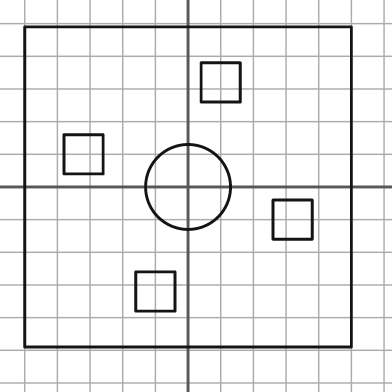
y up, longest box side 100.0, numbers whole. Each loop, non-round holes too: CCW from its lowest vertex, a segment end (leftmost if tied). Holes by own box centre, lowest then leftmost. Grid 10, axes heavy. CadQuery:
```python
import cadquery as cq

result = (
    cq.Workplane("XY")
    .moveTo(-50.0, -49.0)
    .lineTo(50.0, -49.0)
    .lineTo(50.0, 49.0)
    .lineTo(-50.0, 49.0)
    .close()
    .moveTo(-16.0, -38.0)
    .lineTo(-4.0, -38.0)
    .lineTo(-4.0, -26.0)
    .lineTo(-16.0, -26.0)
    .close()
    .moveTo(26.0, -16.0)
    .lineTo(38.0, -16.0)
    .lineTo(38.0, -4.0)
    .lineTo(26.0, -4.0)
    .close()
    .moveTo(0.0, 0.0)
    .circle(13.0)
    .moveTo(-38.0, 4.0)
    .lineTo(-26.0, 4.0)
    .lineTo(-26.0, 16.0)
    .lineTo(-38.0, 16.0)
    .close()
    .moveTo(4.0, 26.0)
    .lineTo(16.0, 26.0)
    .lineTo(16.0, 38.0)
    .lineTo(4.0, 38.0)
    .close()
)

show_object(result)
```